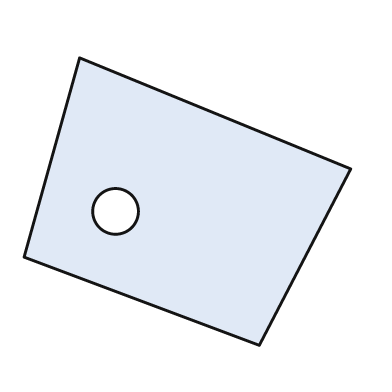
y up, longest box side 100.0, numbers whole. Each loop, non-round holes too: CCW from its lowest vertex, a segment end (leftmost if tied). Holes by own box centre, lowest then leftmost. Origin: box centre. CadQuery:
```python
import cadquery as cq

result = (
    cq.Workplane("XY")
    .moveTo(22.0, -44.0)
    .lineTo(50.0, 10.0)
    .lineTo(-33.0, 44.0)
    .lineTo(-50.0, -17.0)
    .close()
    .moveTo(-22.0, -3.0)
    .circle(7.0)
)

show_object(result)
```